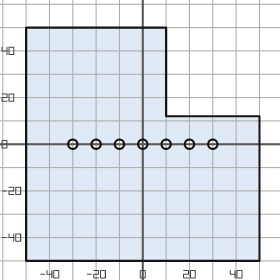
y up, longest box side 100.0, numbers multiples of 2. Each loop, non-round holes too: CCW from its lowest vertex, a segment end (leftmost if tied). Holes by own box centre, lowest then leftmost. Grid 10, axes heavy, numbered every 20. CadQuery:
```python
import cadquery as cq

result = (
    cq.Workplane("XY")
    .moveTo(-50.0, -50.0)
    .lineTo(50.0, -50.0)
    .lineTo(50.0, 12.0)
    .lineTo(10.0, 12.0)
    .lineTo(10.0, 50.0)
    .lineTo(-50.0, 50.0)
    .close()
    .moveTo(-30.0, 0.0)
    .circle(2.0)
    .moveTo(-20.0, 0.0)
    .circle(2.0)
    .moveTo(-10.0, 0.0)
    .circle(2.0)
    .moveTo(0.0, 0.0)
    .circle(2.0)
    .moveTo(10.0, 0.0)
    .circle(2.0)
    .moveTo(20.0, 0.0)
    .circle(2.0)
    .moveTo(30.0, 0.0)
    .circle(2.0)
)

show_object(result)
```